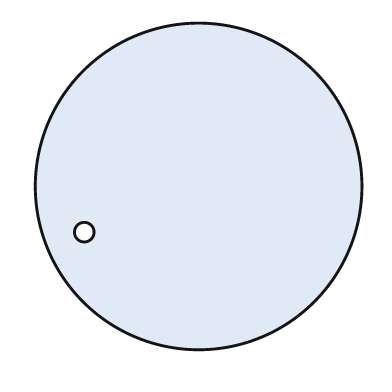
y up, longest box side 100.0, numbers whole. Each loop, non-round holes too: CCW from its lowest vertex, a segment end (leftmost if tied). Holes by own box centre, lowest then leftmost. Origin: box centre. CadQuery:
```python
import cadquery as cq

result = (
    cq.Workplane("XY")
    .moveTo(0.0, 0.0)
    .circle(50.0)
    .moveTo(-35.0, -14.0)
    .circle(3.0)
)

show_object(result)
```